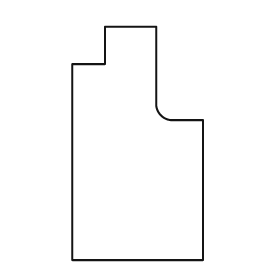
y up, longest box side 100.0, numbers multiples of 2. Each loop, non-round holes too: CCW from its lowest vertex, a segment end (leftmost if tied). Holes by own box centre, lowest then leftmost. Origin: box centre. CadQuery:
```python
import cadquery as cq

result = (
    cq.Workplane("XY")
    .moveTo(-28.0, -50.0)
    .lineTo(28.0, -50.0)
    .lineTo(28.0, 10.0)
    .lineTo(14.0, 10.0)
    .threePointArc((10.0, 12.0), (8.0, 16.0))
    .lineTo(8.0, 50.0)
    .lineTo(-14.0, 50.0)
    .lineTo(-14.0, 34.0)
    .lineTo(-28.0, 34.0)
    .close()
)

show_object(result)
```